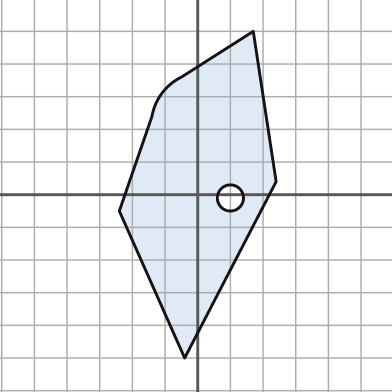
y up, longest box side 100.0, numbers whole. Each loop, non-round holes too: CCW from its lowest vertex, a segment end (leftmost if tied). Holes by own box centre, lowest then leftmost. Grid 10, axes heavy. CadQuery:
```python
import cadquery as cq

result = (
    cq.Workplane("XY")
    .moveTo(-4.0, -50.0)
    .lineTo(24.0, 4.0)
    .lineTo(17.0, 50.0)
    .lineTo(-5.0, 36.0)
    .threePointArc((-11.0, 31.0), (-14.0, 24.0))
    .lineTo(-24.0, -5.0)
    .close()
    .moveTo(10.0, -1.0)
    .circle(4.0)
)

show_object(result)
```